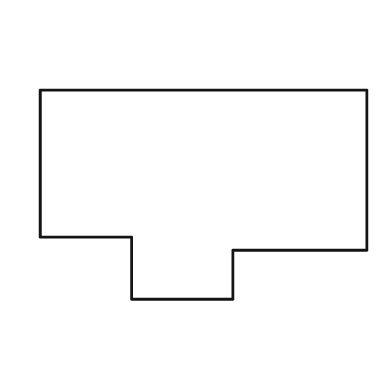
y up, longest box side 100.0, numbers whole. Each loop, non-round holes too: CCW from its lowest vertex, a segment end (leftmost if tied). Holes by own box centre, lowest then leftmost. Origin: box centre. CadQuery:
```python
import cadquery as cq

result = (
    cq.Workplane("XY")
    .moveTo(-22.0, -32.0)
    .lineTo(9.0, -32.0)
    .lineTo(9.0, -17.0)
    .lineTo(50.0, -17.0)
    .lineTo(50.0, 32.0)
    .lineTo(-50.0, 32.0)
    .lineTo(-50.0, -13.0)
    .lineTo(-22.0, -13.0)
    .close()
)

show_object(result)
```